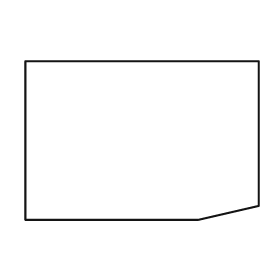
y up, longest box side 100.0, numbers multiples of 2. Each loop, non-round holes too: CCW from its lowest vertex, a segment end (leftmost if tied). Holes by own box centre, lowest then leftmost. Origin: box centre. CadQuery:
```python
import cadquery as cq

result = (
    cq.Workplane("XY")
    .moveTo(-50.0, -34.0)
    .lineTo(24.0, -34.0)
    .lineTo(50.0, -28.0)
    .lineTo(50.0, 34.0)
    .lineTo(-50.0, 34.0)
    .close()
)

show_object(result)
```